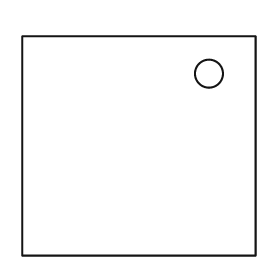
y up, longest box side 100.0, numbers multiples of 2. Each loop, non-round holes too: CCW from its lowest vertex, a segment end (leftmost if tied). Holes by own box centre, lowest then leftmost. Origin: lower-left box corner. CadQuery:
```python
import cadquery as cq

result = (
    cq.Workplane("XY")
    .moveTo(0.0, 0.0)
    .lineTo(100.0, 0.0)
    .lineTo(100.0, 94.0)
    .lineTo(0.0, 94.0)
    .close()
    .moveTo(80.0, 78.0)
    .circle(6.0)
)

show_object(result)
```